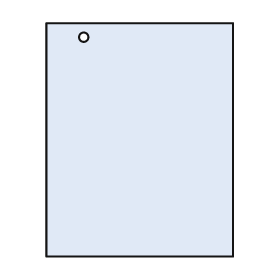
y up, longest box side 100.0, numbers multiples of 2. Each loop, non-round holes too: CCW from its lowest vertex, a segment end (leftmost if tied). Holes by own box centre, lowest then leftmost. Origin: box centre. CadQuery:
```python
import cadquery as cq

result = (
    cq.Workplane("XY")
    .moveTo(-40.0, -50.0)
    .lineTo(40.0, -50.0)
    .lineTo(40.0, 50.0)
    .lineTo(-40.0, 50.0)
    .close()
    .moveTo(-24.0, 44.0)
    .circle(2.0)
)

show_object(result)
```